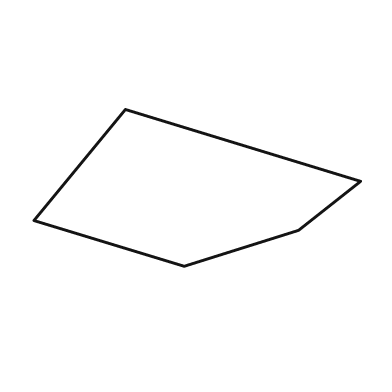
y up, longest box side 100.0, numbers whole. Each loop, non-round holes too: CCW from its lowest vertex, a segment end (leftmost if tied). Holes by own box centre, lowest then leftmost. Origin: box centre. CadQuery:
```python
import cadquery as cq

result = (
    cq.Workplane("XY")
    .moveTo(-4.0, -24.0)
    .lineTo(31.0, -13.0)
    .lineTo(50.0, 2.0)
    .lineTo(-22.0, 24.0)
    .lineTo(-50.0, -10.0)
    .close()
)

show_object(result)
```